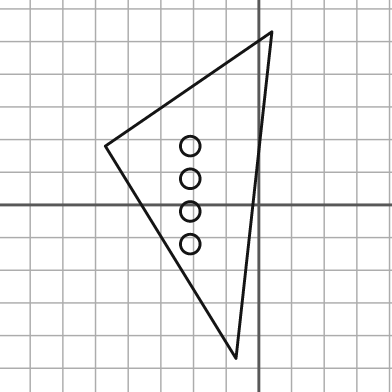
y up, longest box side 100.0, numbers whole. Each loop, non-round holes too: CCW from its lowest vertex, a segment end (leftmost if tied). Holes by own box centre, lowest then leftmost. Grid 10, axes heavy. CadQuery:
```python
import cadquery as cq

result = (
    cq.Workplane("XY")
    .moveTo(-7.0, -47.0)
    .lineTo(4.0, 53.0)
    .lineTo(-47.0, 18.0)
    .close()
    .moveTo(-21.0, -12.0)
    .circle(3.0)
    .moveTo(-21.0, -2.0)
    .circle(3.0)
    .moveTo(-21.0, 8.0)
    .circle(3.0)
    .moveTo(-21.0, 18.0)
    .circle(3.0)
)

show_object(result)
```